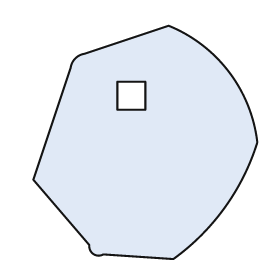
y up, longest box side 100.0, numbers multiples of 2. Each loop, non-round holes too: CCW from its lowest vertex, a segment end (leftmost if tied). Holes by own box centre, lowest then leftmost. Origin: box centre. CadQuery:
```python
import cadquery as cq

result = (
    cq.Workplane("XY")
    .moveTo(12.0, -50.0)
    .threePointArc((34.0, -28.0), (48.0, 0.0))
    .threePointArc((36.0, 30.0), (10.0, 50.0))
    .lineTo(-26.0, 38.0)
    .threePointArc((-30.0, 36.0), (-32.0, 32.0))
    .lineTo(-48.0, -16.0)
    .lineTo(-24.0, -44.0)
    .threePointArc((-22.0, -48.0), (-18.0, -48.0))
    .close()
    .moveTo(-12.0, 14.0)
    .lineTo(0.0, 14.0)
    .lineTo(0.0, 26.0)
    .lineTo(-12.0, 26.0)
    .close()
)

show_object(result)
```